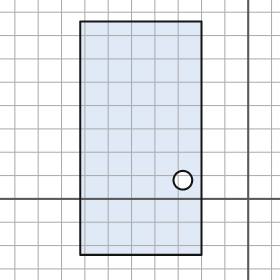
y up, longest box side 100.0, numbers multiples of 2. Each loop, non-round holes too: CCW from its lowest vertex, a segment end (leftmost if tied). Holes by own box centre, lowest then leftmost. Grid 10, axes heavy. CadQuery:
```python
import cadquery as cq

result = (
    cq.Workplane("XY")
    .moveTo(-72.0, -24.0)
    .lineTo(-20.0, -24.0)
    .lineTo(-20.0, 76.0)
    .lineTo(-72.0, 76.0)
    .close()
    .moveTo(-28.0, 8.0)
    .circle(4.0)
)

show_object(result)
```